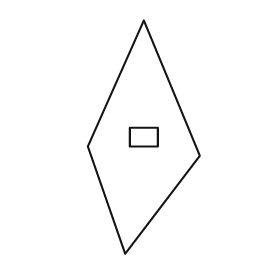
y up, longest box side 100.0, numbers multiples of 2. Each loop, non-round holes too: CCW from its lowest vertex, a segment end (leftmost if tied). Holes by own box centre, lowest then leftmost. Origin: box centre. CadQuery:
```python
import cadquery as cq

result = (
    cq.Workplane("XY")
    .moveTo(-8.0, -50.0)
    .lineTo(24.0, -8.0)
    .lineTo(0.0, 50.0)
    .lineTo(-24.0, -4.0)
    .close()
    .moveTo(-6.0, -4.0)
    .lineTo(6.0, -4.0)
    .lineTo(6.0, 4.0)
    .lineTo(-6.0, 4.0)
    .close()
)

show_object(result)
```